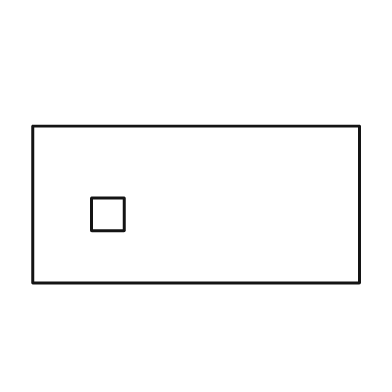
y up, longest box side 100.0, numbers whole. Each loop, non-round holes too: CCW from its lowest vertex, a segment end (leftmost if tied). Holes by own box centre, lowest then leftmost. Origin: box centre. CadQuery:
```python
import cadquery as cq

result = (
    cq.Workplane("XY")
    .moveTo(-50.0, -24.0)
    .lineTo(50.0, -24.0)
    .lineTo(50.0, 24.0)
    .lineTo(-50.0, 24.0)
    .close()
    .moveTo(-32.0, -8.0)
    .lineTo(-22.0, -8.0)
    .lineTo(-22.0, 2.0)
    .lineTo(-32.0, 2.0)
    .close()
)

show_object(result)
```